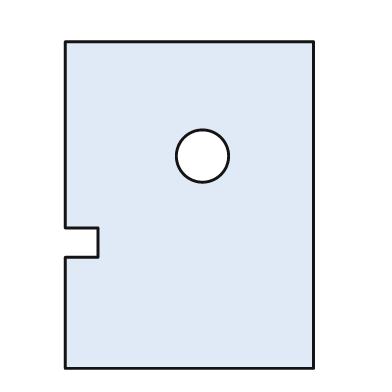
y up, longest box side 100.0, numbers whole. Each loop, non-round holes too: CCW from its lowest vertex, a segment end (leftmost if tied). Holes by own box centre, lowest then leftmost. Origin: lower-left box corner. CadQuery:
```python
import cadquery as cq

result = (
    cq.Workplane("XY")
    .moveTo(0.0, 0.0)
    .lineTo(76.0, 0.0)
    .lineTo(76.0, 100.0)
    .lineTo(0.0, 100.0)
    .lineTo(0.0, 43.0)
    .lineTo(10.0, 43.0)
    .lineTo(10.0, 34.0)
    .lineTo(0.0, 34.0)
    .close()
    .moveTo(42.0, 65.0)
    .circle(8.0)
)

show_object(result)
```